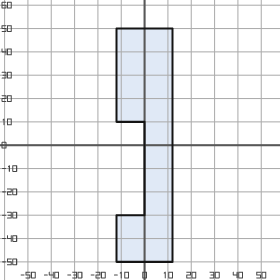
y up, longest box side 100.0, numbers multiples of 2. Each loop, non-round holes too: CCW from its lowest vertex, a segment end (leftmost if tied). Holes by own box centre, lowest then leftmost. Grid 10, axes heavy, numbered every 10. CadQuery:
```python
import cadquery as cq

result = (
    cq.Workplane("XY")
    .moveTo(-12.0, -50.0)
    .lineTo(12.0, -50.0)
    .lineTo(12.0, 50.0)
    .lineTo(-12.0, 50.0)
    .lineTo(-12.0, 10.0)
    .lineTo(0.0, 10.0)
    .lineTo(0.0, -30.0)
    .lineTo(-12.0, -30.0)
    .close()
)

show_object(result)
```